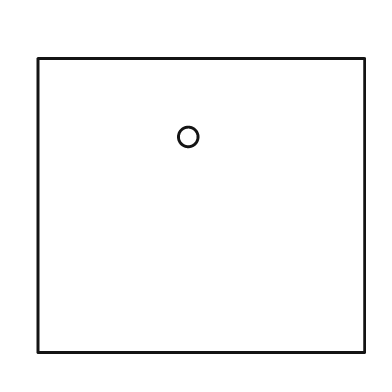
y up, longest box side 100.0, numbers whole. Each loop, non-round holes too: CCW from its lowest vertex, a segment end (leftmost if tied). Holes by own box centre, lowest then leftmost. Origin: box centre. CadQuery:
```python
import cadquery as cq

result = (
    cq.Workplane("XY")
    .moveTo(-50.0, -45.0)
    .lineTo(50.0, -45.0)
    .lineTo(50.0, 45.0)
    .lineTo(-50.0, 45.0)
    .close()
    .moveTo(-4.0, 21.0)
    .circle(3.0)
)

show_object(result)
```